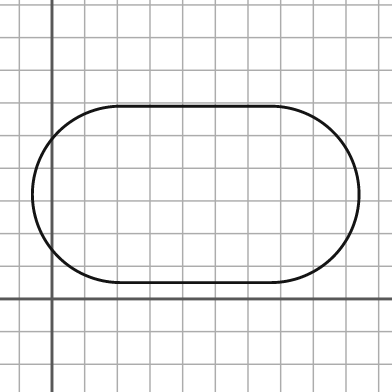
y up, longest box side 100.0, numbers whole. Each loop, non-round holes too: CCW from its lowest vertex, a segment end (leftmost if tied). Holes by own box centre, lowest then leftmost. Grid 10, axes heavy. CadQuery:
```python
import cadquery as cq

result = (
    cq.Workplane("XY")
    .moveTo(21.0, 5.0)
    .lineTo(67.0, 5.0)
    .threePointArc((94.0, 32.0), (67.0, 59.0))
    .lineTo(21.0, 59.0)
    .threePointArc((-6.0, 32.0), (21.0, 5.0))
    .close()
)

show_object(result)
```